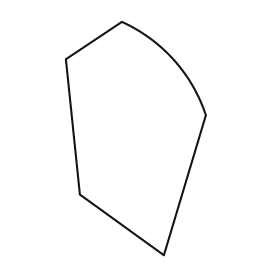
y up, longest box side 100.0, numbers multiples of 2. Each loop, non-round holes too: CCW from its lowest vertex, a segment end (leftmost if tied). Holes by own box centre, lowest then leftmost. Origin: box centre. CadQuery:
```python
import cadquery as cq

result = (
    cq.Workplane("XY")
    .moveTo(12.0, -50.0)
    .lineTo(30.0, 10.0)
    .threePointArc((16.0, 34.0), (-6.0, 50.0))
    .lineTo(-30.0, 34.0)
    .lineTo(-24.0, -24.0)
    .close()
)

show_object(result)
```